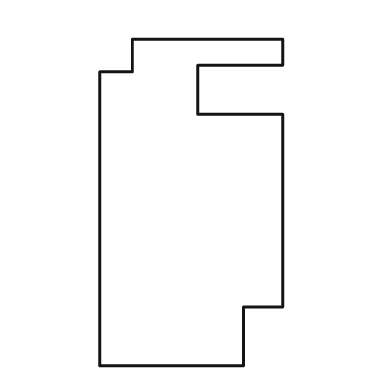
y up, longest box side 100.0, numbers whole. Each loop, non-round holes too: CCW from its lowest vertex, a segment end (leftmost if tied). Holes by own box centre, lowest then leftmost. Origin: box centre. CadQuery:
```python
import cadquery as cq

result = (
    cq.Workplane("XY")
    .moveTo(-28.0, -50.0)
    .lineTo(16.0, -50.0)
    .lineTo(16.0, -32.0)
    .lineTo(28.0, -32.0)
    .lineTo(28.0, 27.0)
    .lineTo(2.0, 27.0)
    .lineTo(2.0, 42.0)
    .lineTo(28.0, 42.0)
    .lineTo(28.0, 50.0)
    .lineTo(-18.0, 50.0)
    .lineTo(-18.0, 40.0)
    .lineTo(-28.0, 40.0)
    .close()
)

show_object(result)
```